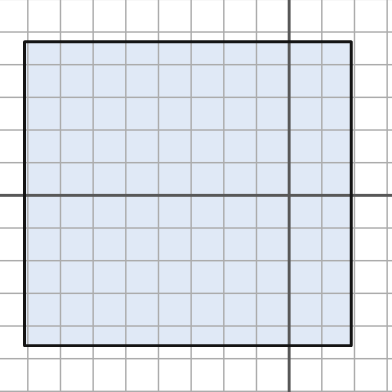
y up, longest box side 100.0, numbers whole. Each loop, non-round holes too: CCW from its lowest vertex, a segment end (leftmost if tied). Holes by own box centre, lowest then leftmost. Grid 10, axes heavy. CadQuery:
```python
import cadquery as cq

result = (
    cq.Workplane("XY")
    .moveTo(-81.0, -46.0)
    .lineTo(19.0, -46.0)
    .lineTo(19.0, 47.0)
    .lineTo(-81.0, 47.0)
    .close()
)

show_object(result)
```